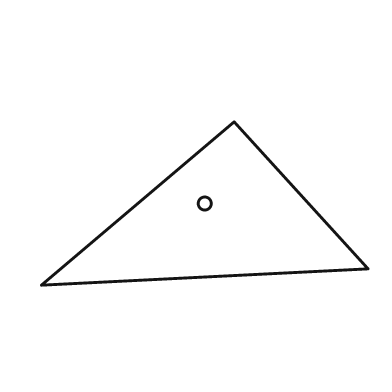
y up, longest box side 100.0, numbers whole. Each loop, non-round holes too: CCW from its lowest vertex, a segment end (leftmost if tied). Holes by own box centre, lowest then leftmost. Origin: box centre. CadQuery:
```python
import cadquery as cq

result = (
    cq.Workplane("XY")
    .moveTo(-50.0, -25.0)
    .lineTo(50.0, -20.0)
    .lineTo(9.0, 25.0)
    .close()
    .moveTo(0.0, 0.0)
    .circle(2.0)
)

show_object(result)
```